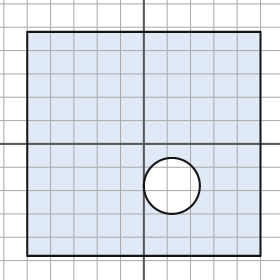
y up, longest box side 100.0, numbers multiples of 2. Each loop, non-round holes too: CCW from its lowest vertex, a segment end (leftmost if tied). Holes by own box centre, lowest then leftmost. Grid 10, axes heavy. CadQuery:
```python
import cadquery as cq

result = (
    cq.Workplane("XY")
    .moveTo(-50.0, -48.0)
    .lineTo(50.0, -48.0)
    .lineTo(50.0, 48.0)
    .lineTo(-50.0, 48.0)
    .close()
    .moveTo(12.0, -18.0)
    .circle(12.0)
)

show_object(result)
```